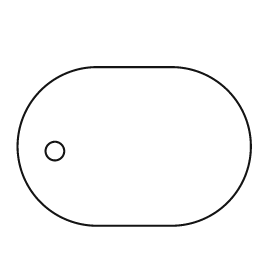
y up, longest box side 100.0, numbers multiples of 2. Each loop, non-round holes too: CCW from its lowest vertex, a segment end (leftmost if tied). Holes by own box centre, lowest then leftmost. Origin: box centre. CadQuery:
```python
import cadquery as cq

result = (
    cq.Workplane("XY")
    .moveTo(-16.0, -34.0)
    .lineTo(16.0, -34.0)
    .threePointArc((50.0, 0.0), (16.0, 34.0))
    .lineTo(-16.0, 34.0)
    .threePointArc((-50.0, 0.0), (-16.0, -34.0))
    .close()
    .moveTo(-34.0, -2.0)
    .circle(4.0)
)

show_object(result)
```